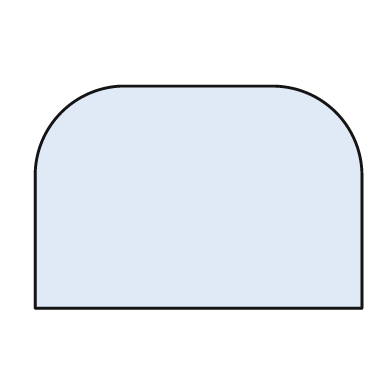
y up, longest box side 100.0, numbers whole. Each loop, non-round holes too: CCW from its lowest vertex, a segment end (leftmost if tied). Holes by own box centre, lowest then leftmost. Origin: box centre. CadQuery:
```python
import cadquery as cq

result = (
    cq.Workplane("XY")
    .moveTo(-50.0, -34.0)
    .lineTo(50.0, -34.0)
    .lineTo(50.0, 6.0)
    .threePointArc((42.0, 26.0), (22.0, 34.0))
    .lineTo(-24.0, 34.0)
    .threePointArc((-42.0, 26.0), (-50.0, 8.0))
    .close()
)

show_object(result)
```